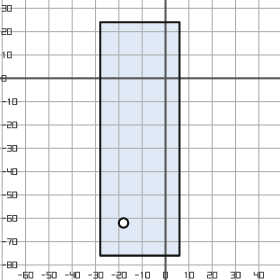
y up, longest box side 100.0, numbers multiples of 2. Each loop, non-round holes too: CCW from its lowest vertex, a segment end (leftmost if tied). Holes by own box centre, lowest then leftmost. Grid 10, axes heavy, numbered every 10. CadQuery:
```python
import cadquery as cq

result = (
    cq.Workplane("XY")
    .moveTo(-28.0, -76.0)
    .lineTo(6.0, -76.0)
    .lineTo(6.0, 24.0)
    .lineTo(-28.0, 24.0)
    .close()
    .moveTo(-18.0, -62.0)
    .circle(2.0)
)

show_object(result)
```